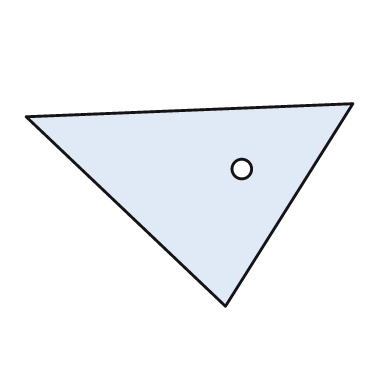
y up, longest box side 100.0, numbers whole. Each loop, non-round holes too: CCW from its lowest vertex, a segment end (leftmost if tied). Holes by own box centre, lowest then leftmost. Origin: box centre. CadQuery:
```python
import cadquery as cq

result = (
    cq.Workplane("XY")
    .moveTo(11.0, -31.0)
    .lineTo(50.0, 31.0)
    .lineTo(-50.0, 27.0)
    .close()
    .moveTo(16.0, 11.0)
    .circle(3.0)
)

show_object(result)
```